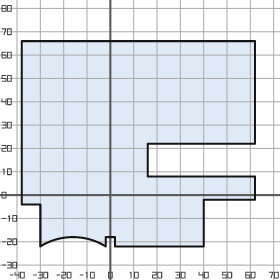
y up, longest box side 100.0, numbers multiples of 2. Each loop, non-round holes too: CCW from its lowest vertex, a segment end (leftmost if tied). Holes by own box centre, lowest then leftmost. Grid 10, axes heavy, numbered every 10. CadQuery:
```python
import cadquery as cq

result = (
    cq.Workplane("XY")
    .moveTo(-30.0, -22.0)
    .threePointArc((-16.0, -18.0), (-2.0, -22.0))
    .lineTo(-2.0, -18.0)
    .lineTo(2.0, -18.0)
    .lineTo(2.0, -22.0)
    .lineTo(40.0, -22.0)
    .lineTo(40.0, -2.0)
    .lineTo(62.0, -2.0)
    .lineTo(62.0, 8.0)
    .lineTo(16.0, 8.0)
    .lineTo(16.0, 22.0)
    .lineTo(62.0, 22.0)
    .lineTo(62.0, 66.0)
    .lineTo(-38.0, 66.0)
    .lineTo(-38.0, -4.0)
    .lineTo(-30.0, -4.0)
    .close()
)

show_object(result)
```